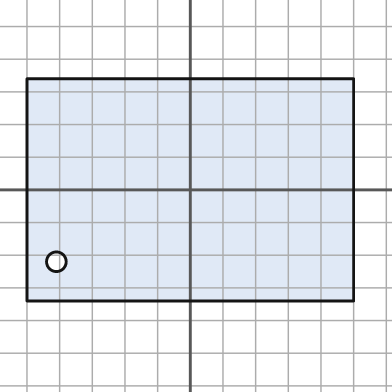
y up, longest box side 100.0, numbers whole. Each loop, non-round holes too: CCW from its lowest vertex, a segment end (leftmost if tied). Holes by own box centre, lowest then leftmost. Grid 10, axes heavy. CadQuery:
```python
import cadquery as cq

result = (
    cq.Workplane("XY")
    .moveTo(-50.0, -34.0)
    .lineTo(50.0, -34.0)
    .lineTo(50.0, 34.0)
    .lineTo(-50.0, 34.0)
    .close()
    .moveTo(-41.0, -22.0)
    .circle(3.0)
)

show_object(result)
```